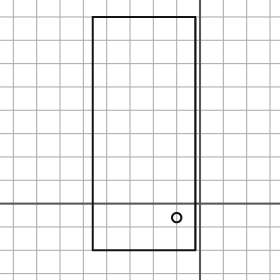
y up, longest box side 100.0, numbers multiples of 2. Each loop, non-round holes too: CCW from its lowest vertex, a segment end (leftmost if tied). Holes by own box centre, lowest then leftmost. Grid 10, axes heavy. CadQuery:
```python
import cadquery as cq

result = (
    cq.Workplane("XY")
    .moveTo(-46.0, -20.0)
    .lineTo(-2.0, -20.0)
    .lineTo(-2.0, 80.0)
    .lineTo(-46.0, 80.0)
    .close()
    .moveTo(-10.0, -6.0)
    .circle(2.0)
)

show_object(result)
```